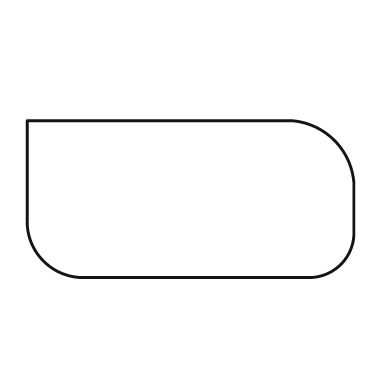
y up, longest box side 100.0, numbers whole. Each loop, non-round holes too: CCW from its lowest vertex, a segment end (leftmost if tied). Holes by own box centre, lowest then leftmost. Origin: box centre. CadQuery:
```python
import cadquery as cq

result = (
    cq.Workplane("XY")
    .moveTo(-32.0, -24.0)
    .lineTo(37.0, -24.0)
    .threePointArc((46.0, -20.0), (50.0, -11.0))
    .lineTo(50.0, 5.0)
    .threePointArc((44.0, 18.0), (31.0, 24.0))
    .lineTo(-50.0, 24.0)
    .lineTo(-50.0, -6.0)
    .threePointArc((-45.0, -19.0), (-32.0, -24.0))
    .close()
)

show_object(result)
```